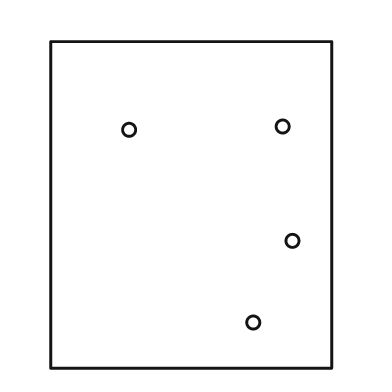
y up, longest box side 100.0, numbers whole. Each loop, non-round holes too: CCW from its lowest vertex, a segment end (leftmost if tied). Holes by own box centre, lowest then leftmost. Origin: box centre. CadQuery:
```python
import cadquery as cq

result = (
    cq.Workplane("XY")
    .moveTo(-43.0, -50.0)
    .lineTo(43.0, -50.0)
    .lineTo(43.0, 50.0)
    .lineTo(-43.0, 50.0)
    .close()
    .moveTo(19.0, -36.0)
    .circle(2.0)
    .moveTo(31.0, -11.0)
    .circle(2.0)
    .moveTo(-19.0, 23.0)
    .circle(2.0)
    .moveTo(28.0, 24.0)
    .circle(2.0)
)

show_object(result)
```